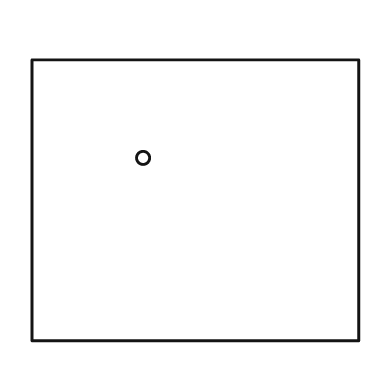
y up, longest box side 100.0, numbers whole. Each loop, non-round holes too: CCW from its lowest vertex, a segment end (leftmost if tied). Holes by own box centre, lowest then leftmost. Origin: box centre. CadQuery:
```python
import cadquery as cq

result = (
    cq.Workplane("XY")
    .moveTo(-50.0, -43.0)
    .lineTo(50.0, -43.0)
    .lineTo(50.0, 43.0)
    .lineTo(-50.0, 43.0)
    .close()
    .moveTo(-16.0, 13.0)
    .circle(2.0)
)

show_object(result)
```